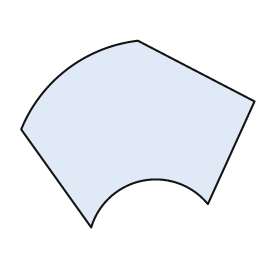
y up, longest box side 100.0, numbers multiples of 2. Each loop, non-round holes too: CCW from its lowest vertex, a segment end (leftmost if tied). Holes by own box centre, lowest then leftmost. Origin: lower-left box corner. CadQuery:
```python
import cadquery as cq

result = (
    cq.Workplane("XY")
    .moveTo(30.0, 0.0)
    .threePointArc((52.0, 20.0), (80.0, 10.0))
    .lineTo(100.0, 54.0)
    .lineTo(50.0, 80.0)
    .threePointArc((20.0, 68.0), (0.0, 42.0))
    .close()
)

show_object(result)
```